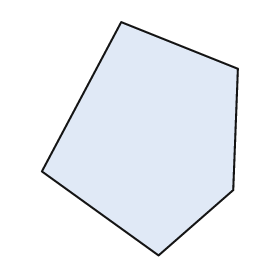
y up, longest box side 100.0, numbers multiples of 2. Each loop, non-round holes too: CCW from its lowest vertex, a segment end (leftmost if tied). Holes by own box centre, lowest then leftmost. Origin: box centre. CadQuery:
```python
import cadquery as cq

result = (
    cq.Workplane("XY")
    .moveTo(8.0, -50.0)
    .lineTo(40.0, -22.0)
    .lineTo(42.0, 30.0)
    .lineTo(-8.0, 50.0)
    .lineTo(-42.0, -14.0)
    .close()
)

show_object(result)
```